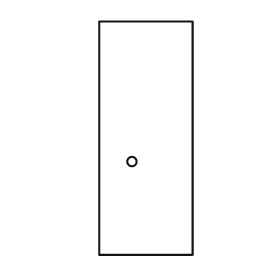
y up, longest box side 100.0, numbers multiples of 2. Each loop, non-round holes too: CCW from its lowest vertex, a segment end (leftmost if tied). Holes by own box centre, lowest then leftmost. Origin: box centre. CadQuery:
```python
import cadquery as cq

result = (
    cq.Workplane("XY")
    .moveTo(-20.0, -50.0)
    .lineTo(20.0, -50.0)
    .lineTo(20.0, 50.0)
    .lineTo(-20.0, 50.0)
    .close()
    .moveTo(-6.0, -10.0)
    .circle(2.0)
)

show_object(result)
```